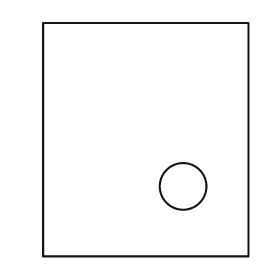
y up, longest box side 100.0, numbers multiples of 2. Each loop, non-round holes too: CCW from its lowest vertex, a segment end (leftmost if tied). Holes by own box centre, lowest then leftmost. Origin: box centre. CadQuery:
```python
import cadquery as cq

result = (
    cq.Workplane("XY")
    .moveTo(-44.0, -50.0)
    .lineTo(44.0, -50.0)
    .lineTo(44.0, 50.0)
    .lineTo(-44.0, 50.0)
    .close()
    .moveTo(16.0, -20.0)
    .circle(10.0)
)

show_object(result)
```